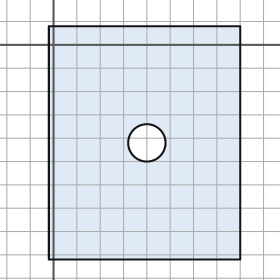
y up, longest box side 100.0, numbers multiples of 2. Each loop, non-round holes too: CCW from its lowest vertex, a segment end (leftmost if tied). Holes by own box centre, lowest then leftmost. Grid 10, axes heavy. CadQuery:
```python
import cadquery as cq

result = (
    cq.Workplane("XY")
    .moveTo(-2.0, -92.0)
    .lineTo(80.0, -92.0)
    .lineTo(80.0, 8.0)
    .lineTo(-2.0, 8.0)
    .close()
    .moveTo(40.0, -42.0)
    .circle(8.0)
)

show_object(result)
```